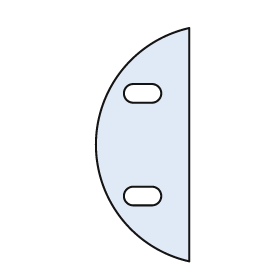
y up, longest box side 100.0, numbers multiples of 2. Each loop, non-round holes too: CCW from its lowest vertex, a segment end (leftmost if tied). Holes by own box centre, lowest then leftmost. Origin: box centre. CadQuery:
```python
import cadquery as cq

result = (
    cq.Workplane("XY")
    .moveTo(20.0, -50.0)
    .lineTo(20.0, 50.0)
    .threePointArc((-20.0, 0.0), (20.0, -50.0))
    .close()
    .moveTo(-4.0, -26.0)
    .lineTo(4.0, -26.0)
    .threePointArc((8.0, -22.0), (4.0, -18.0))
    .lineTo(-4.0, -18.0)
    .threePointArc((-8.0, -22.0), (-4.0, -26.0))
    .close()
    .moveTo(-4.0, 18.0)
    .lineTo(4.0, 18.0)
    .threePointArc((8.0, 22.0), (4.0, 26.0))
    .lineTo(-4.0, 26.0)
    .threePointArc((-8.0, 22.0), (-4.0, 18.0))
    .close()
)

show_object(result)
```